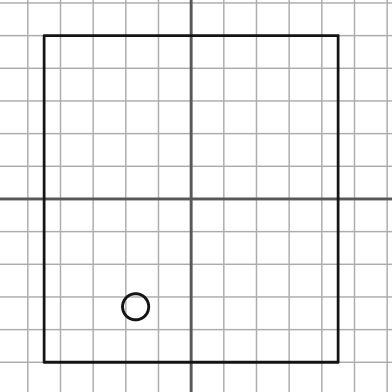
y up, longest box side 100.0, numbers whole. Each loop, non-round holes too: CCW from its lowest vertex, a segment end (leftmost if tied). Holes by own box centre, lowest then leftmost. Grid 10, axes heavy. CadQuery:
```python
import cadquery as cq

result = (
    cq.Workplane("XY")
    .moveTo(-45.0, -50.0)
    .lineTo(45.0, -50.0)
    .lineTo(45.0, 50.0)
    .lineTo(-45.0, 50.0)
    .close()
    .moveTo(-17.0, -33.0)
    .circle(4.0)
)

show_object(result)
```